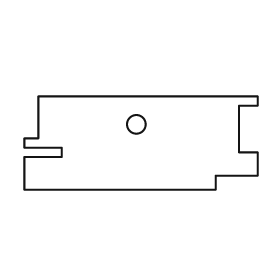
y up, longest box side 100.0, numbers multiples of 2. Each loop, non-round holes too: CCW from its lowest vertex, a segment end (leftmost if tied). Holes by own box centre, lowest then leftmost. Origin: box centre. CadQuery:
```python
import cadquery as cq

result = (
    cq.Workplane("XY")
    .moveTo(-50.0, -20.0)
    .lineTo(32.0, -20.0)
    .lineTo(32.0, -14.0)
    .lineTo(50.0, -14.0)
    .lineTo(50.0, -4.0)
    .lineTo(42.0, -4.0)
    .lineTo(42.0, 16.0)
    .lineTo(50.0, 16.0)
    .lineTo(50.0, 20.0)
    .lineTo(-44.0, 20.0)
    .lineTo(-44.0, 2.0)
    .lineTo(-50.0, 2.0)
    .lineTo(-50.0, -2.0)
    .lineTo(-34.0, -2.0)
    .lineTo(-34.0, -6.0)
    .lineTo(-50.0, -6.0)
    .close()
    .moveTo(-2.0, 8.0)
    .circle(4.0)
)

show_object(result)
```